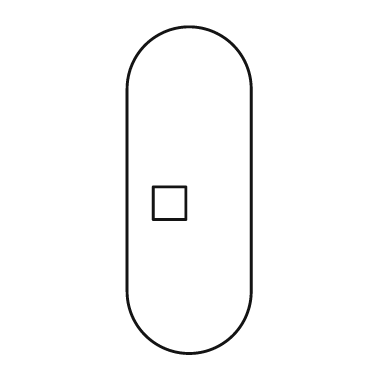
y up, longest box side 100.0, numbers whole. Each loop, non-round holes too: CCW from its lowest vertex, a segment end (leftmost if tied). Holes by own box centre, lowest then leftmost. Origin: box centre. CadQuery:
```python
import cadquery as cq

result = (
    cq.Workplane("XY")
    .moveTo(-19.0, -31.0)
    .threePointArc((0.0, -50.0), (19.0, -31.0))
    .lineTo(19.0, 31.0)
    .threePointArc((0.0, 50.0), (-19.0, 31.0))
    .close()
    .moveTo(-11.0, -9.0)
    .lineTo(-1.0, -9.0)
    .lineTo(-1.0, 1.0)
    .lineTo(-11.0, 1.0)
    .close()
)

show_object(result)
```